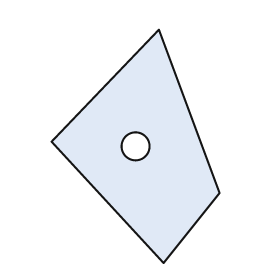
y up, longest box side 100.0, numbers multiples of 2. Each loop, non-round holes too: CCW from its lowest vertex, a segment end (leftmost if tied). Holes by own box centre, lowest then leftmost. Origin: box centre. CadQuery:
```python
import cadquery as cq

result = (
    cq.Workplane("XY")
    .moveTo(12.0, -50.0)
    .lineTo(36.0, -20.0)
    .lineTo(10.0, 50.0)
    .lineTo(-36.0, 2.0)
    .close()
    .moveTo(0.0, 0.0)
    .circle(6.0)
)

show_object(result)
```